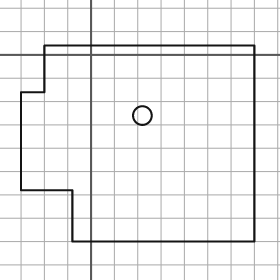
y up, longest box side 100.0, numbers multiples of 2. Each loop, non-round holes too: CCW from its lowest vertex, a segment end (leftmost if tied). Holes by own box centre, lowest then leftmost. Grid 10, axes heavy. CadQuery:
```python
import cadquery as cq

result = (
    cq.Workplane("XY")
    .moveTo(-8.0, -80.0)
    .lineTo(70.0, -80.0)
    .lineTo(70.0, 4.0)
    .lineTo(-20.0, 4.0)
    .lineTo(-20.0, -16.0)
    .lineTo(-30.0, -16.0)
    .lineTo(-30.0, -58.0)
    .lineTo(-8.0, -58.0)
    .close()
    .moveTo(22.0, -26.0)
    .circle(4.0)
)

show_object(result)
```